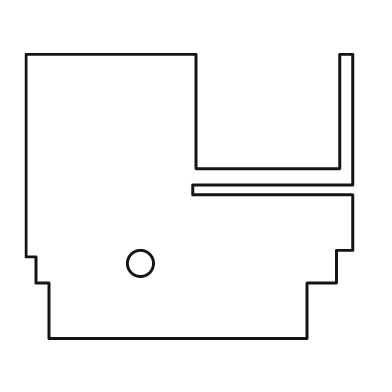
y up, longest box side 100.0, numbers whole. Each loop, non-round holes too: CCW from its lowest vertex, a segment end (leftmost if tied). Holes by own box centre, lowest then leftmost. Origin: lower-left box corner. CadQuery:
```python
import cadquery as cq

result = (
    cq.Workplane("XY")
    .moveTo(7.0, 0.0)
    .lineTo(86.0, 0.0)
    .lineTo(86.0, 17.0)
    .lineTo(95.0, 17.0)
    .lineTo(95.0, 27.0)
    .lineTo(100.0, 27.0)
    .lineTo(100.0, 44.0)
    .lineTo(51.0, 44.0)
    .lineTo(51.0, 47.0)
    .lineTo(100.0, 47.0)
    .lineTo(100.0, 87.0)
    .lineTo(96.0, 87.0)
    .lineTo(96.0, 52.0)
    .lineTo(52.0, 52.0)
    .lineTo(52.0, 87.0)
    .lineTo(0.0, 87.0)
    .lineTo(0.0, 25.0)
    .lineTo(3.0, 25.0)
    .lineTo(3.0, 17.0)
    .lineTo(7.0, 17.0)
    .close()
    .moveTo(35.0, 23.0)
    .circle(4.0)
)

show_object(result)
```